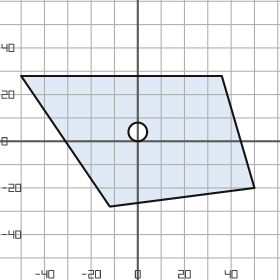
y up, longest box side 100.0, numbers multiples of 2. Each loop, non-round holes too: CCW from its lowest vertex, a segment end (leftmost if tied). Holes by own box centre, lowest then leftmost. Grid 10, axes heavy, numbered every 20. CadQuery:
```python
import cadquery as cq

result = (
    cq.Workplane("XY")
    .moveTo(-12.0, -28.0)
    .lineTo(50.0, -20.0)
    .lineTo(36.0, 28.0)
    .lineTo(-50.0, 28.0)
    .close()
    .moveTo(0.0, 4.0)
    .circle(4.0)
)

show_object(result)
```